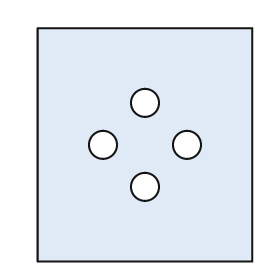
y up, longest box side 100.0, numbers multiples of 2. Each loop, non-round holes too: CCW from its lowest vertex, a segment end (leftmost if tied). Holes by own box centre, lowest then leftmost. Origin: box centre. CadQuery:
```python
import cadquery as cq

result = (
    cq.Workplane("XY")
    .moveTo(-46.0, -50.0)
    .lineTo(46.0, -50.0)
    .lineTo(46.0, 50.0)
    .lineTo(-46.0, 50.0)
    .close()
    .moveTo(0.0, -18.0)
    .circle(6.0)
    .moveTo(-18.0, 0.0)
    .circle(6.0)
    .moveTo(18.0, 0.0)
    .circle(6.0)
    .moveTo(0.0, 18.0)
    .circle(6.0)
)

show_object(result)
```